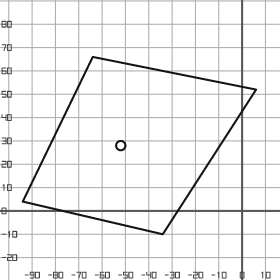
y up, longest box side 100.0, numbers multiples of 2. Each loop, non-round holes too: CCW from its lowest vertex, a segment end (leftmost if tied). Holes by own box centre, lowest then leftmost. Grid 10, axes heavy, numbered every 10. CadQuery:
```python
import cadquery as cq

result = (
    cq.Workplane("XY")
    .moveTo(-34.0, -10.0)
    .lineTo(6.0, 52.0)
    .lineTo(-64.0, 66.0)
    .lineTo(-94.0, 4.0)
    .close()
    .moveTo(-52.0, 28.0)
    .circle(2.0)
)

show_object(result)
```